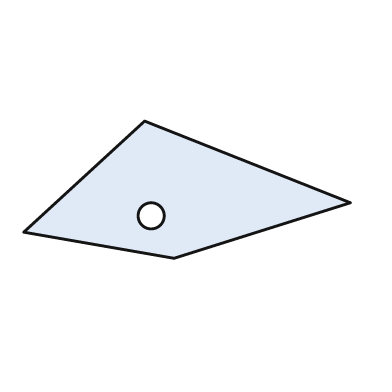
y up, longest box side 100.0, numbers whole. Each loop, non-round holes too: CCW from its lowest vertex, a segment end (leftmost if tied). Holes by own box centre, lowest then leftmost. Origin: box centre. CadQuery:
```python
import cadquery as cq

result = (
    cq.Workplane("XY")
    .moveTo(-4.0, -21.0)
    .lineTo(50.0, -4.0)
    .lineTo(-13.0, 21.0)
    .lineTo(-50.0, -13.0)
    .close()
    .moveTo(-11.0, -8.0)
    .circle(4.0)
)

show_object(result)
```